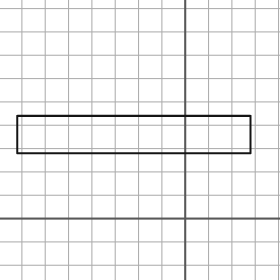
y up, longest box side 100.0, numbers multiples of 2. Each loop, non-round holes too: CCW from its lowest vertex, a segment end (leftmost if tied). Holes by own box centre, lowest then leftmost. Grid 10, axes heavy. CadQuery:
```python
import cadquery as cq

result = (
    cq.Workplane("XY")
    .moveTo(-72.0, 28.0)
    .lineTo(28.0, 28.0)
    .lineTo(28.0, 44.0)
    .lineTo(-72.0, 44.0)
    .close()
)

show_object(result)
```